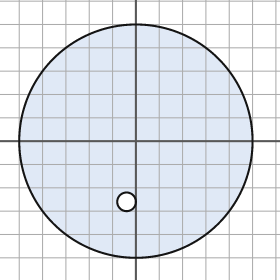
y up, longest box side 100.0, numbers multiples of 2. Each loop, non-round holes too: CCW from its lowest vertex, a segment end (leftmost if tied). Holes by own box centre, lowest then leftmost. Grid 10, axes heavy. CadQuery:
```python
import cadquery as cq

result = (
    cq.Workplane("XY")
    .moveTo(0.0, 0.0)
    .circle(50.0)
    .moveTo(-4.0, -26.0)
    .circle(4.0)
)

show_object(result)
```